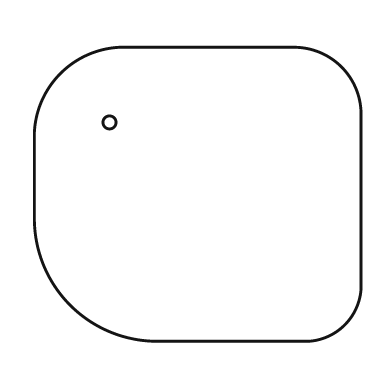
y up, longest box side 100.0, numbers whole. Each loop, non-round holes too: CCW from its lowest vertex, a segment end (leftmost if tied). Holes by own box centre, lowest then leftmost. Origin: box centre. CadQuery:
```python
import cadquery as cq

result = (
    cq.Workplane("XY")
    .moveTo(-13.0, -45.0)
    .lineTo(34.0, -45.0)
    .threePointArc((45.0, -40.0), (50.0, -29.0))
    .lineTo(50.0, 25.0)
    .threePointArc((44.0, 39.0), (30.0, 45.0))
    .lineTo(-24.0, 45.0)
    .threePointArc((-42.0, 37.0), (-50.0, 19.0))
    .lineTo(-50.0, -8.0)
    .threePointArc((-39.0, -34.0), (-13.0, -45.0))
    .close()
    .moveTo(-27.0, 22.0)
    .circle(2.0)
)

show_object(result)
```